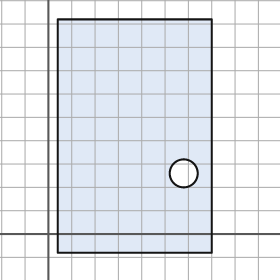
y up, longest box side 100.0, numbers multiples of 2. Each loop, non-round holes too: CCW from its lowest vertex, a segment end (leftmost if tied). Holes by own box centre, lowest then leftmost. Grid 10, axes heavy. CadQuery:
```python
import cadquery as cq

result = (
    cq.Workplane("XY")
    .moveTo(4.0, -8.0)
    .lineTo(70.0, -8.0)
    .lineTo(70.0, 92.0)
    .lineTo(4.0, 92.0)
    .close()
    .moveTo(58.0, 26.0)
    .circle(6.0)
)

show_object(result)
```